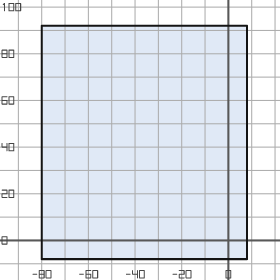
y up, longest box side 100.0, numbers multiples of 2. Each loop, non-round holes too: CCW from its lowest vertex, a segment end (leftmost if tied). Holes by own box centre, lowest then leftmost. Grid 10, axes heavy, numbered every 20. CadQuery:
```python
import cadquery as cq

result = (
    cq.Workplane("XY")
    .moveTo(-80.0, -8.0)
    .lineTo(8.0, -8.0)
    .lineTo(8.0, 92.0)
    .lineTo(-80.0, 92.0)
    .close()
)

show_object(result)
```